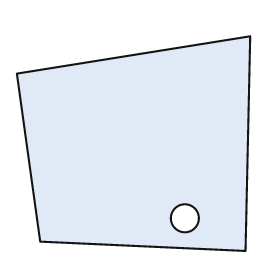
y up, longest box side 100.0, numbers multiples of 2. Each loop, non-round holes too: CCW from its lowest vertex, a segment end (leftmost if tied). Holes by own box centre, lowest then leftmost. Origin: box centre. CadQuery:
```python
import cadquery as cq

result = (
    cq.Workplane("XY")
    .moveTo(48.0, -46.0)
    .lineTo(50.0, 46.0)
    .lineTo(-50.0, 30.0)
    .lineTo(-40.0, -42.0)
    .close()
    .moveTo(22.0, -32.0)
    .circle(6.0)
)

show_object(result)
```